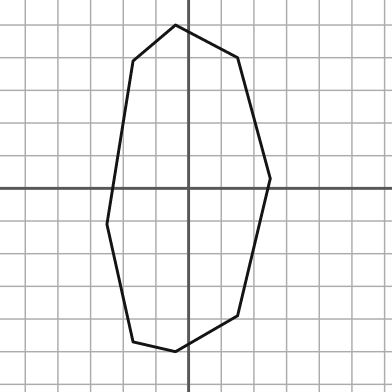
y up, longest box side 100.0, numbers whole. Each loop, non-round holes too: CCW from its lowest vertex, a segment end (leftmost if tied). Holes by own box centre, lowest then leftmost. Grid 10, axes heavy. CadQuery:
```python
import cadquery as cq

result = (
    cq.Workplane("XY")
    .moveTo(-4.0, -50.0)
    .lineTo(15.0, -39.0)
    .lineTo(25.0, 3.0)
    .lineTo(15.0, 40.0)
    .lineTo(-4.0, 50.0)
    .lineTo(-17.0, 39.0)
    .lineTo(-25.0, -11.0)
    .lineTo(-17.0, -47.0)
    .close()
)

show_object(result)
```